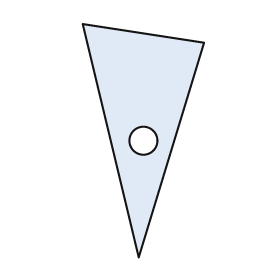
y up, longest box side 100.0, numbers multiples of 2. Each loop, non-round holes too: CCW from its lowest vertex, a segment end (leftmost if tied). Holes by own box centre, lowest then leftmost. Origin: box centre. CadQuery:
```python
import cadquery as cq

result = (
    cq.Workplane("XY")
    .moveTo(-2.0, -50.0)
    .lineTo(26.0, 42.0)
    .lineTo(-26.0, 50.0)
    .close()
    .moveTo(0.0, 0.0)
    .circle(6.0)
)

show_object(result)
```